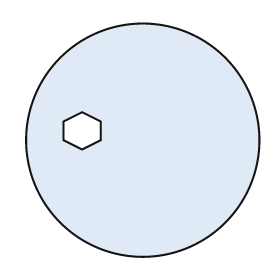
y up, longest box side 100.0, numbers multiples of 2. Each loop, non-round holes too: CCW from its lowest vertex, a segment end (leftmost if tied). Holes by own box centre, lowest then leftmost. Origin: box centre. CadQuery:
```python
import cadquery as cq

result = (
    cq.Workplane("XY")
    .moveTo(0.0, 0.0)
    .circle(50.0)
    .moveTo(-26.0, -4.0)
    .lineTo(-18.0, 0.0)
    .lineTo(-18.0, 8.0)
    .lineTo(-26.0, 12.0)
    .lineTo(-34.0, 8.0)
    .lineTo(-34.0, 0.0)
    .close()
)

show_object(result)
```